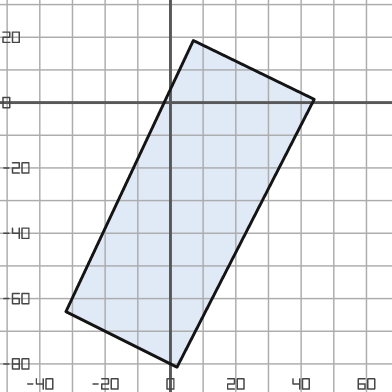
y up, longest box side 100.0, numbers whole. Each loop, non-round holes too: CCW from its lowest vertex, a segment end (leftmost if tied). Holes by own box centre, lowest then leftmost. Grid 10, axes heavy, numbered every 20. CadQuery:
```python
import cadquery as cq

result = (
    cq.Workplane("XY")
    .moveTo(2.0, -81.0)
    .lineTo(44.0, 1.0)
    .lineTo(7.0, 19.0)
    .lineTo(-32.0, -64.0)
    .close()
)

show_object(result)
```